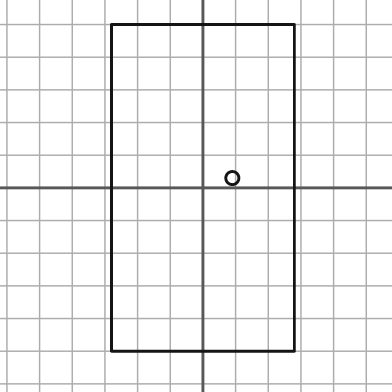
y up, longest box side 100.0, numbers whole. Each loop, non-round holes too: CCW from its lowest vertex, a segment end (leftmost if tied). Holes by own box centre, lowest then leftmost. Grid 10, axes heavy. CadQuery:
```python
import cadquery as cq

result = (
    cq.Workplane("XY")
    .moveTo(-28.0, -50.0)
    .lineTo(28.0, -50.0)
    .lineTo(28.0, 50.0)
    .lineTo(-28.0, 50.0)
    .close()
    .moveTo(9.0, 3.0)
    .circle(2.0)
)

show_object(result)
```